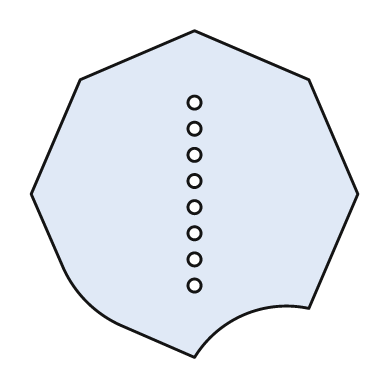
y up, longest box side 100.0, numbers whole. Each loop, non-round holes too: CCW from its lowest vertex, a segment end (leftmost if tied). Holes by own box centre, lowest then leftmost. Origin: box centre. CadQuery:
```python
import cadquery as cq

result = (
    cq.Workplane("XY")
    .moveTo(0.0, -50.0)
    .threePointArc((15.0, -37.0), (35.0, -35.0))
    .lineTo(50.0, 0.0)
    .lineTo(35.0, 35.0)
    .lineTo(0.0, 50.0)
    .lineTo(-35.0, 35.0)
    .lineTo(-50.0, 0.0)
    .lineTo(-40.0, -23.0)
    .threePointArc((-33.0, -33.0), (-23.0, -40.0))
    .close()
    .moveTo(0.0, -28.0)
    .circle(2.0)
    .moveTo(0.0, -20.0)
    .circle(2.0)
    .moveTo(0.0, -12.0)
    .circle(2.0)
    .moveTo(0.0, -4.0)
    .circle(2.0)
    .moveTo(0.0, 4.0)
    .circle(2.0)
    .moveTo(0.0, 12.0)
    .circle(2.0)
    .moveTo(0.0, 20.0)
    .circle(2.0)
    .moveTo(0.0, 28.0)
    .circle(2.0)
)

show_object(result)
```